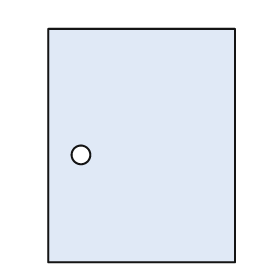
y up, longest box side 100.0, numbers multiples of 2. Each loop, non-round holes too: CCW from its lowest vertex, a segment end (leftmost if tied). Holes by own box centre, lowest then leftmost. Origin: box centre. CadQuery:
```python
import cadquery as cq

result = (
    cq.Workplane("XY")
    .moveTo(-40.0, -50.0)
    .lineTo(40.0, -50.0)
    .lineTo(40.0, 50.0)
    .lineTo(-40.0, 50.0)
    .close()
    .moveTo(-26.0, -4.0)
    .circle(4.0)
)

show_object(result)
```